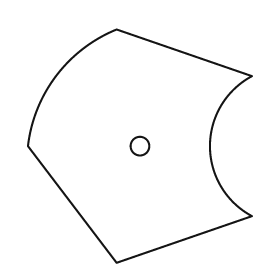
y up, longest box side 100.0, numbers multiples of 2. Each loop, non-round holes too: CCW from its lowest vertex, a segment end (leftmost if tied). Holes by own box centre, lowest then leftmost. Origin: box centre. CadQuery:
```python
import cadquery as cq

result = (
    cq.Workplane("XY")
    .moveTo(-10.0, -50.0)
    .lineTo(48.0, -30.0)
    .threePointArc((30.0, 0.0), (48.0, 30.0))
    .lineTo(-10.0, 50.0)
    .threePointArc((-36.0, 30.0), (-48.0, 0.0))
    .close()
    .moveTo(0.0, 0.0)
    .circle(4.0)
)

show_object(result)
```